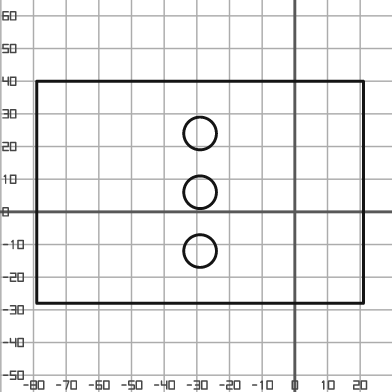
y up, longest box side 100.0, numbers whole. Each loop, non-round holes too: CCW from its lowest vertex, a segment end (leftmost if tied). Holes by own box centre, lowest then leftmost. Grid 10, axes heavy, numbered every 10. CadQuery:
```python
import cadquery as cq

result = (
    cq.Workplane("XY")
    .moveTo(-79.0, -28.0)
    .lineTo(21.0, -28.0)
    .lineTo(21.0, 40.0)
    .lineTo(-79.0, 40.0)
    .close()
    .moveTo(-29.0, -12.0)
    .circle(5.0)
    .moveTo(-29.0, 6.0)
    .circle(5.0)
    .moveTo(-29.0, 24.0)
    .circle(5.0)
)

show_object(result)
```